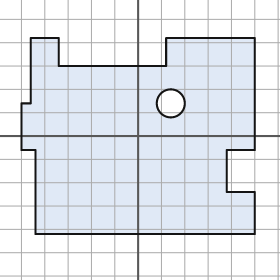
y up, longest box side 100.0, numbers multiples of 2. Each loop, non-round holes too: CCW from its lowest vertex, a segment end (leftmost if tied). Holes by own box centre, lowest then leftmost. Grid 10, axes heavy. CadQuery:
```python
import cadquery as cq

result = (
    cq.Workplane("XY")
    .moveTo(-44.0, -42.0)
    .lineTo(50.0, -42.0)
    .lineTo(50.0, -24.0)
    .lineTo(38.0, -24.0)
    .lineTo(38.0, -6.0)
    .lineTo(50.0, -6.0)
    .lineTo(50.0, 42.0)
    .lineTo(12.0, 42.0)
    .lineTo(12.0, 30.0)
    .lineTo(-34.0, 30.0)
    .lineTo(-34.0, 42.0)
    .lineTo(-46.0, 42.0)
    .lineTo(-46.0, 14.0)
    .lineTo(-50.0, 14.0)
    .lineTo(-50.0, -6.0)
    .lineTo(-44.0, -6.0)
    .close()
    .moveTo(14.0, 14.0)
    .circle(6.0)
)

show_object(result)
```